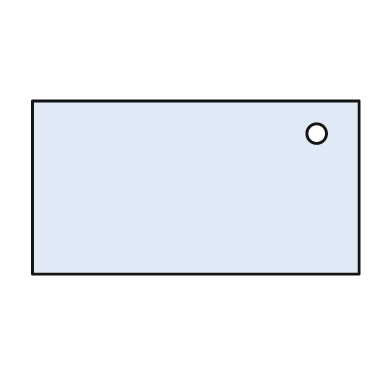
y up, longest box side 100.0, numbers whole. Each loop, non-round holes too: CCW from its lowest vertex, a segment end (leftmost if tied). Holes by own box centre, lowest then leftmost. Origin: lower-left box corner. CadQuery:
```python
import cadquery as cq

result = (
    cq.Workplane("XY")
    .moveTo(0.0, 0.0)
    .lineTo(100.0, 0.0)
    .lineTo(100.0, 53.0)
    .lineTo(0.0, 53.0)
    .close()
    .moveTo(87.0, 43.0)
    .circle(3.0)
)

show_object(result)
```